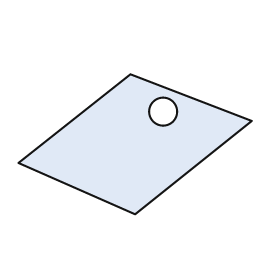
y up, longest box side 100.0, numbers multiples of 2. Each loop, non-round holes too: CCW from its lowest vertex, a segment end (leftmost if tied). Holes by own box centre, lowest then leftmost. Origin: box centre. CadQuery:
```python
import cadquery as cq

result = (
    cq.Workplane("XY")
    .moveTo(0.0, -30.0)
    .lineTo(50.0, 10.0)
    .lineTo(-2.0, 30.0)
    .lineTo(-50.0, -8.0)
    .close()
    .moveTo(12.0, 14.0)
    .circle(6.0)
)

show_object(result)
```